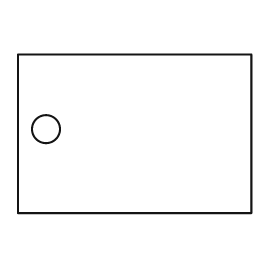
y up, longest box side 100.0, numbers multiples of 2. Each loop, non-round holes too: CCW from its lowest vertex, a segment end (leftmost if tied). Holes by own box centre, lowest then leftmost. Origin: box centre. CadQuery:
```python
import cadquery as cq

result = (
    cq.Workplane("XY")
    .moveTo(-50.0, -34.0)
    .lineTo(50.0, -34.0)
    .lineTo(50.0, 34.0)
    .lineTo(-50.0, 34.0)
    .close()
    .moveTo(-38.0, 2.0)
    .circle(6.0)
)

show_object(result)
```